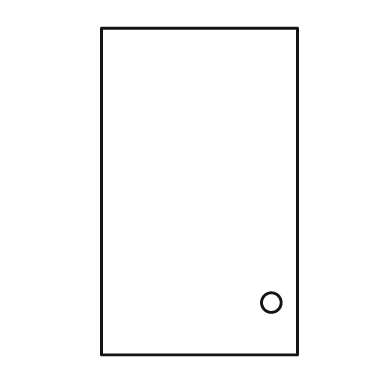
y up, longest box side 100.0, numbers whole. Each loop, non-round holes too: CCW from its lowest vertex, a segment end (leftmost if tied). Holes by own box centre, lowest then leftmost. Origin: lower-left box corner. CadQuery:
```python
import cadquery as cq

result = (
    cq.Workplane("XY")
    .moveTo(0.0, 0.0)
    .lineTo(60.0, 0.0)
    .lineTo(60.0, 100.0)
    .lineTo(0.0, 100.0)
    .close()
    .moveTo(52.0, 16.0)
    .circle(3.0)
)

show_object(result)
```